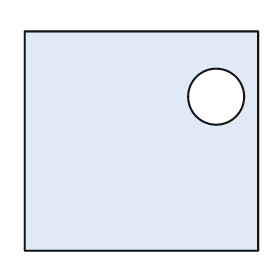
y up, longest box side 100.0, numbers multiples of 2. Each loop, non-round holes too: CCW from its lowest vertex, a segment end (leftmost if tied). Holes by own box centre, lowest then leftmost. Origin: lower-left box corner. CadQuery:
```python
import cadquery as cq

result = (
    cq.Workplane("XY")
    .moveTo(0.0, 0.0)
    .lineTo(100.0, 0.0)
    .lineTo(100.0, 94.0)
    .lineTo(0.0, 94.0)
    .close()
    .moveTo(82.0, 66.0)
    .circle(12.0)
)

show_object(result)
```